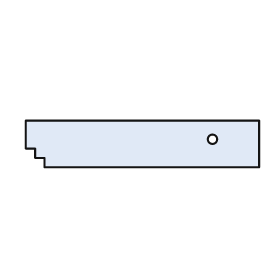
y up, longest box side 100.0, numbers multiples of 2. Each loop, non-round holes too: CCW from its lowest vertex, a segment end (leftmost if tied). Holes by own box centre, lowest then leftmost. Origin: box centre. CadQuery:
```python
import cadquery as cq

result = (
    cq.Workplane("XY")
    .moveTo(-42.0, -10.0)
    .lineTo(50.0, -10.0)
    .lineTo(50.0, 10.0)
    .lineTo(-50.0, 10.0)
    .lineTo(-50.0, -2.0)
    .lineTo(-46.0, -2.0)
    .lineTo(-46.0, -6.0)
    .lineTo(-42.0, -6.0)
    .close()
    .moveTo(30.0, 2.0)
    .circle(2.0)
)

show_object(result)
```